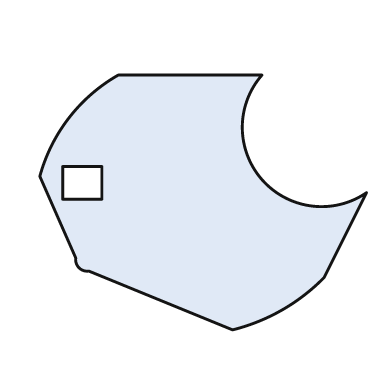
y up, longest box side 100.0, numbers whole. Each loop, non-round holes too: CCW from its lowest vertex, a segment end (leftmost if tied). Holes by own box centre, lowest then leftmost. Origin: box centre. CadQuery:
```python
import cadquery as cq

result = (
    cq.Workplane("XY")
    .moveTo(9.0, -39.0)
    .threePointArc((24.0, -33.0), (37.0, -23.0))
    .lineTo(50.0, 3.0)
    .threePointArc((18.0, 7.0), (18.0, 39.0))
    .lineTo(-26.0, 39.0)
    .threePointArc((-41.0, 26.0), (-50.0, 8.0))
    .lineTo(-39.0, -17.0)
    .threePointArc((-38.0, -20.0), (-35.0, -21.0))
    .close()
    .moveTo(-43.0, 1.0)
    .lineTo(-31.0, 1.0)
    .lineTo(-31.0, 11.0)
    .lineTo(-43.0, 11.0)
    .close()
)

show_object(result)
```